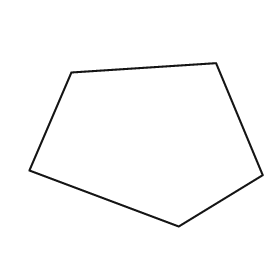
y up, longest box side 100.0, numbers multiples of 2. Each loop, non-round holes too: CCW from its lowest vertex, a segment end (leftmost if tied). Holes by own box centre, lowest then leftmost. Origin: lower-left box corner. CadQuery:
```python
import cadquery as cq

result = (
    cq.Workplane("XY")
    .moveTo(64.0, 0.0)
    .lineTo(100.0, 22.0)
    .lineTo(80.0, 70.0)
    .lineTo(18.0, 66.0)
    .lineTo(0.0, 24.0)
    .close()
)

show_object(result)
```